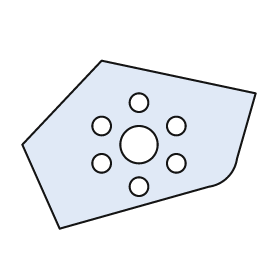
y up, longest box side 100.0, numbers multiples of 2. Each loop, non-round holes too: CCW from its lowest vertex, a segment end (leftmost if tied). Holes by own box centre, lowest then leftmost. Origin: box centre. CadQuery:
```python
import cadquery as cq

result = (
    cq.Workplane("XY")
    .moveTo(-34.0, -36.0)
    .lineTo(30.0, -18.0)
    .threePointArc((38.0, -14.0), (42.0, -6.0))
    .lineTo(50.0, 22.0)
    .lineTo(-16.0, 36.0)
    .lineTo(-50.0, 0.0)
    .close()
    .moveTo(0.0, -18.0)
    .circle(4.0)
    .moveTo(-16.0, -8.0)
    .circle(4.0)
    .moveTo(16.0, -8.0)
    .circle(4.0)
    .moveTo(0.0, 0.0)
    .circle(8.0)
    .moveTo(-16.0, 8.0)
    .circle(4.0)
    .moveTo(16.0, 8.0)
    .circle(4.0)
    .moveTo(0.0, 18.0)
    .circle(4.0)
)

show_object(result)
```